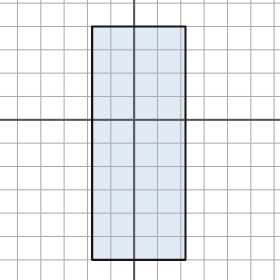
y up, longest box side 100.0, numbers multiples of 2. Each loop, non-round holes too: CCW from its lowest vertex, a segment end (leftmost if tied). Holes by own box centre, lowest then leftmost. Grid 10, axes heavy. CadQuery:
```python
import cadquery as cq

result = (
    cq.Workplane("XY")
    .moveTo(-18.0, -60.0)
    .lineTo(22.0, -60.0)
    .lineTo(22.0, 40.0)
    .lineTo(-18.0, 40.0)
    .close()
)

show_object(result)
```